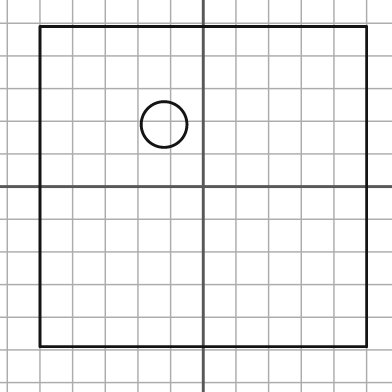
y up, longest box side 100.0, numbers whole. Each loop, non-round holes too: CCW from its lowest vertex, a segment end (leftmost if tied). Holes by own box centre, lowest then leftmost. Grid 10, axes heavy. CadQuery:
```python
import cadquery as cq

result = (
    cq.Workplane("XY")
    .moveTo(-50.0, -49.0)
    .lineTo(50.0, -49.0)
    .lineTo(50.0, 49.0)
    .lineTo(-50.0, 49.0)
    .close()
    .moveTo(-12.0, 19.0)
    .circle(7.0)
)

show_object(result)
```